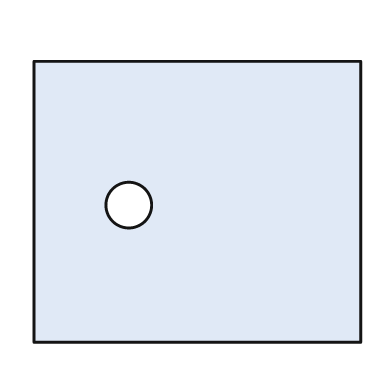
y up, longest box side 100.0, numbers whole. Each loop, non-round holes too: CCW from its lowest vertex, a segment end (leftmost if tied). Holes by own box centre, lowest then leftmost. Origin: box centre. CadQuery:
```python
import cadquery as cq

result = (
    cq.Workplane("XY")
    .moveTo(-50.0, -43.0)
    .lineTo(50.0, -43.0)
    .lineTo(50.0, 43.0)
    .lineTo(-50.0, 43.0)
    .close()
    .moveTo(-21.0, -1.0)
    .circle(7.0)
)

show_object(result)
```